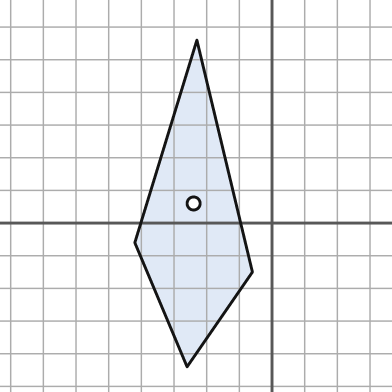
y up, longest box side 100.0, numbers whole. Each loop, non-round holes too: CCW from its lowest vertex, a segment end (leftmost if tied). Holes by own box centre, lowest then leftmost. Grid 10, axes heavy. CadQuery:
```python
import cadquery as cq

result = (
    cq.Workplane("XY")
    .moveTo(-26.0, -44.0)
    .lineTo(-6.0, -15.0)
    .lineTo(-23.0, 56.0)
    .lineTo(-42.0, -6.0)
    .close()
    .moveTo(-24.0, 6.0)
    .circle(2.0)
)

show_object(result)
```